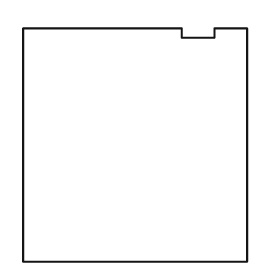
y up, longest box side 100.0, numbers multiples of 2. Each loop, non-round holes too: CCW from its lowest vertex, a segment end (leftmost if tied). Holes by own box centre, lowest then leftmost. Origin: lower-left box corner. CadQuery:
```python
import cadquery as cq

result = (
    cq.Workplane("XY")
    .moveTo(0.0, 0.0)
    .lineTo(96.0, 0.0)
    .lineTo(96.0, 100.0)
    .lineTo(82.0, 100.0)
    .lineTo(82.0, 96.0)
    .lineTo(68.0, 96.0)
    .lineTo(68.0, 100.0)
    .lineTo(0.0, 100.0)
    .close()
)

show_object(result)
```